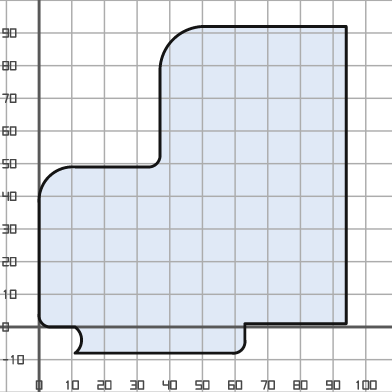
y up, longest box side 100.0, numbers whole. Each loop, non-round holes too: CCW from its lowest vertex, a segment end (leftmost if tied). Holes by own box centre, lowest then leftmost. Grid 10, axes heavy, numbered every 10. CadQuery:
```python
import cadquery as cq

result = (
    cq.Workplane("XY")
    .moveTo(11.0, -8.0)
    .lineTo(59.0, -8.0)
    .threePointArc((62.0, -7.0), (63.0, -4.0))
    .lineTo(63.0, 1.0)
    .lineTo(94.0, 1.0)
    .lineTo(94.0, 92.0)
    .lineTo(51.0, 92.0)
    .threePointArc((41.0, 88.0), (37.0, 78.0))
    .lineTo(37.0, 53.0)
    .threePointArc((36.0, 50.0), (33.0, 49.0))
    .lineTo(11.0, 49.0)
    .threePointArc((3.0, 46.0), (0.0, 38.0))
    .lineTo(0.0, 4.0)
    .threePointArc((1.0, 1.0), (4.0, 0.0))
    .lineTo(11.0, 0.0)
    .threePointArc((13.0, -4.0), (11.0, -8.0))
    .close()
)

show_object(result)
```